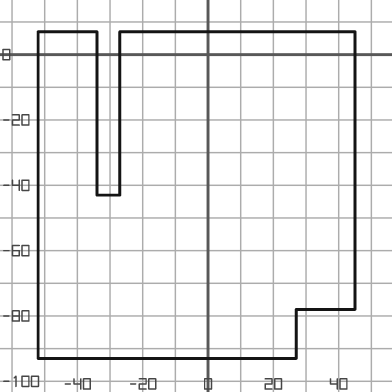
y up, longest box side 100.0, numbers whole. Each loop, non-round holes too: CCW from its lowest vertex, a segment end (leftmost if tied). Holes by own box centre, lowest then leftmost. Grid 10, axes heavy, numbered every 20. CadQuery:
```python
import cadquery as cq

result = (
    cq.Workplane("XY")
    .moveTo(-52.0, -93.0)
    .lineTo(27.0, -93.0)
    .lineTo(27.0, -78.0)
    .lineTo(45.0, -78.0)
    .lineTo(45.0, 7.0)
    .lineTo(-27.0, 7.0)
    .lineTo(-27.0, -43.0)
    .lineTo(-34.0, -43.0)
    .lineTo(-34.0, 7.0)
    .lineTo(-52.0, 7.0)
    .close()
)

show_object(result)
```